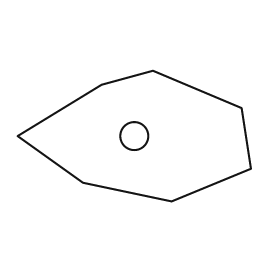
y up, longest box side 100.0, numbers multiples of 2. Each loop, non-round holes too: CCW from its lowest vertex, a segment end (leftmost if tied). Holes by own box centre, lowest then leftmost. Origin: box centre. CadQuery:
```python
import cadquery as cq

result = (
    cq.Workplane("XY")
    .moveTo(16.0, -28.0)
    .lineTo(50.0, -14.0)
    .lineTo(46.0, 12.0)
    .lineTo(8.0, 28.0)
    .lineTo(-14.0, 22.0)
    .lineTo(-50.0, 0.0)
    .lineTo(-22.0, -20.0)
    .close()
    .moveTo(0.0, 0.0)
    .circle(6.0)
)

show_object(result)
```